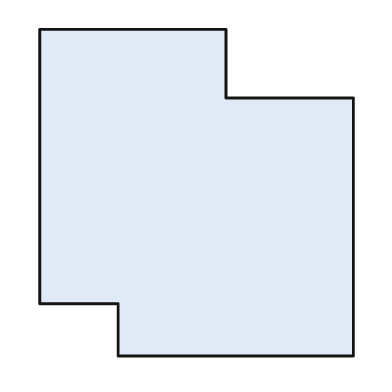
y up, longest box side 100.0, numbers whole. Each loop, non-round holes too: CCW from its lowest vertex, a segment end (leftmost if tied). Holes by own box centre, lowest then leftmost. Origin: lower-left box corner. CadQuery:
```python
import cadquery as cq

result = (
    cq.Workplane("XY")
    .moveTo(24.0, 0.0)
    .lineTo(96.0, 0.0)
    .lineTo(96.0, 79.0)
    .lineTo(57.0, 79.0)
    .lineTo(57.0, 100.0)
    .lineTo(0.0, 100.0)
    .lineTo(0.0, 16.0)
    .lineTo(24.0, 16.0)
    .close()
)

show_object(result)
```